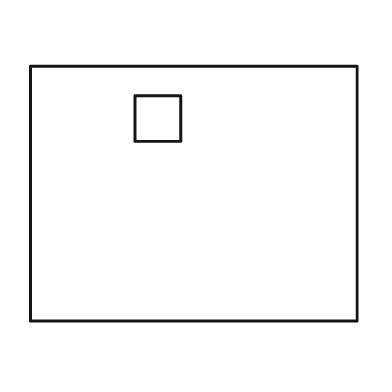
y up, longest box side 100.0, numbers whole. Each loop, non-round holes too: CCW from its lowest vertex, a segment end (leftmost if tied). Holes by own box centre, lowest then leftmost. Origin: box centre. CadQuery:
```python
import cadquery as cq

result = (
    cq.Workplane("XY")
    .moveTo(-50.0, -39.0)
    .lineTo(50.0, -39.0)
    .lineTo(50.0, 39.0)
    .lineTo(-50.0, 39.0)
    .close()
    .moveTo(-18.0, 16.0)
    .lineTo(-4.0, 16.0)
    .lineTo(-4.0, 30.0)
    .lineTo(-18.0, 30.0)
    .close()
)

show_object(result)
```